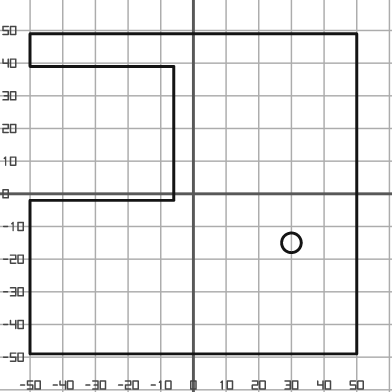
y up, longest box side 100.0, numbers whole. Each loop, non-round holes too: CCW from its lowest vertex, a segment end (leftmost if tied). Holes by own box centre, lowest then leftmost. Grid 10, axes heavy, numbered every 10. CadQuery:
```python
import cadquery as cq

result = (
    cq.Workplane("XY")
    .moveTo(-50.0, -49.0)
    .lineTo(50.0, -49.0)
    .lineTo(50.0, 49.0)
    .lineTo(-50.0, 49.0)
    .lineTo(-50.0, 39.0)
    .lineTo(-6.0, 39.0)
    .lineTo(-6.0, -2.0)
    .lineTo(-50.0, -2.0)
    .close()
    .moveTo(30.0, -15.0)
    .circle(3.0)
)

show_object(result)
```